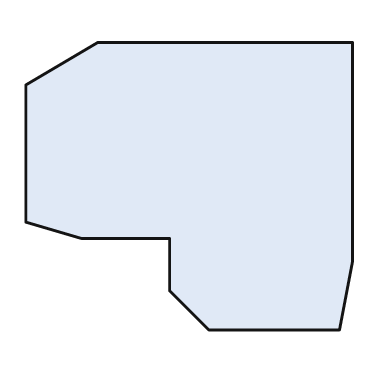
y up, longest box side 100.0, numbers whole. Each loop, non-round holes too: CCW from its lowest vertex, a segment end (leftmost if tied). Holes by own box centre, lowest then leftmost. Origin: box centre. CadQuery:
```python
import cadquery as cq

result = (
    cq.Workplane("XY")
    .moveTo(6.0, -44.0)
    .lineTo(46.0, -44.0)
    .lineTo(50.0, -23.0)
    .lineTo(50.0, 44.0)
    .lineTo(-28.0, 44.0)
    .lineTo(-50.0, 31.0)
    .lineTo(-50.0, -11.0)
    .lineTo(-33.0, -16.0)
    .lineTo(-6.0, -16.0)
    .lineTo(-6.0, -32.0)
    .close()
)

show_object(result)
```